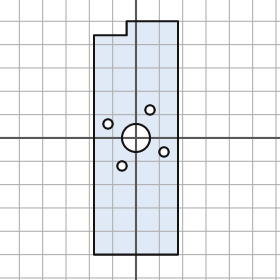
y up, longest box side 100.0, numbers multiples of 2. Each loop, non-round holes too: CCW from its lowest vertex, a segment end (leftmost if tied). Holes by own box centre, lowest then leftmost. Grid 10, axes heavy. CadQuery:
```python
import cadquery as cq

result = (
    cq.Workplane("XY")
    .moveTo(-18.0, -50.0)
    .lineTo(18.0, -50.0)
    .lineTo(18.0, 50.0)
    .lineTo(-4.0, 50.0)
    .lineTo(-4.0, 44.0)
    .lineTo(-18.0, 44.0)
    .close()
    .moveTo(-6.0, -12.0)
    .circle(2.0)
    .moveTo(12.0, -6.0)
    .circle(2.0)
    .moveTo(0.0, 0.0)
    .circle(6.0)
    .moveTo(-12.0, 6.0)
    .circle(2.0)
    .moveTo(6.0, 12.0)
    .circle(2.0)
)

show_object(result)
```